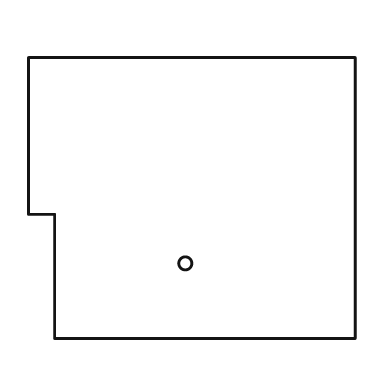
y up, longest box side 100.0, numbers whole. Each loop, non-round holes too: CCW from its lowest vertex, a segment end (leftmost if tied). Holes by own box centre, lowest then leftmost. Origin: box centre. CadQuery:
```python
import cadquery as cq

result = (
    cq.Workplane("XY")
    .moveTo(-42.0, -43.0)
    .lineTo(50.0, -43.0)
    .lineTo(50.0, 43.0)
    .lineTo(-50.0, 43.0)
    .lineTo(-50.0, -5.0)
    .lineTo(-42.0, -5.0)
    .close()
    .moveTo(-2.0, -20.0)
    .circle(2.0)
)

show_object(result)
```